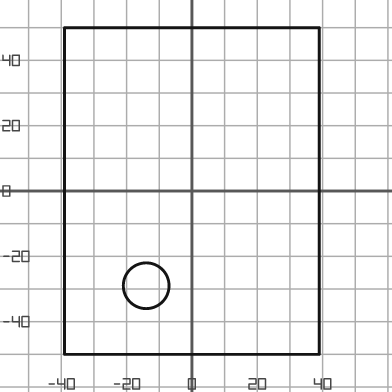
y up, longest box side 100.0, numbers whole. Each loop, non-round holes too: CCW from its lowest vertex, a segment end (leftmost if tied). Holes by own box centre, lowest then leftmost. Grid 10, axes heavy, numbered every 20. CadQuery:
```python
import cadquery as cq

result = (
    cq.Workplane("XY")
    .moveTo(-39.0, -50.0)
    .lineTo(39.0, -50.0)
    .lineTo(39.0, 50.0)
    .lineTo(-39.0, 50.0)
    .close()
    .moveTo(-14.0, -29.0)
    .circle(7.0)
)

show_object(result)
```